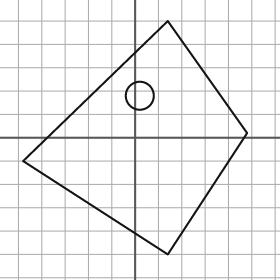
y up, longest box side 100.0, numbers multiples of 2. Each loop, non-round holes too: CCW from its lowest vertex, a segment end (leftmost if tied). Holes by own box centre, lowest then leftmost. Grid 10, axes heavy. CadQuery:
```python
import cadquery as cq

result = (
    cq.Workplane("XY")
    .moveTo(14.0, -50.0)
    .lineTo(48.0, 2.0)
    .lineTo(14.0, 50.0)
    .lineTo(-48.0, -10.0)
    .close()
    .moveTo(2.0, 18.0)
    .circle(6.0)
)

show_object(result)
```